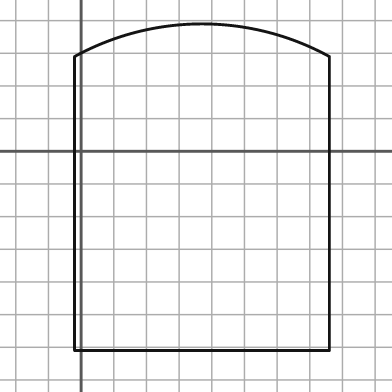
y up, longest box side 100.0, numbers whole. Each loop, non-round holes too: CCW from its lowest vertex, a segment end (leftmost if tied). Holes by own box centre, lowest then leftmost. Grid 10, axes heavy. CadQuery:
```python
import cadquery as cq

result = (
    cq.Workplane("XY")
    .moveTo(-2.0, -61.0)
    .lineTo(76.0, -61.0)
    .lineTo(76.0, 29.0)
    .threePointArc((37.0, 39.0), (-2.0, 29.0))
    .close()
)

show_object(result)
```